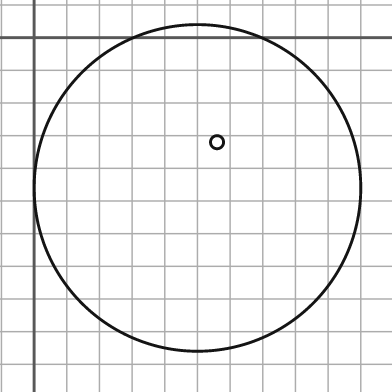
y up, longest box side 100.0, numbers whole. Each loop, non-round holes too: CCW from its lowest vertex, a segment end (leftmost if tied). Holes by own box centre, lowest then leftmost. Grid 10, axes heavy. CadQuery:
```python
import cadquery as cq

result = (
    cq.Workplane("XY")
    .moveTo(50.0, -46.0)
    .circle(50.0)
    .moveTo(56.0, -32.0)
    .circle(2.0)
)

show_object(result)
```